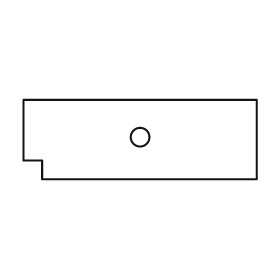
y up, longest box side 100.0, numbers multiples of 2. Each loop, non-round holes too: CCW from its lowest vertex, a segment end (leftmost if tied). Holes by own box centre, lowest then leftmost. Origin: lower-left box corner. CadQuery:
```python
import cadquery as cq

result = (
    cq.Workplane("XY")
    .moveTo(8.0, 0.0)
    .lineTo(100.0, 0.0)
    .lineTo(100.0, 34.0)
    .lineTo(0.0, 34.0)
    .lineTo(0.0, 8.0)
    .lineTo(8.0, 8.0)
    .close()
    .moveTo(50.0, 18.0)
    .circle(4.0)
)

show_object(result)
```